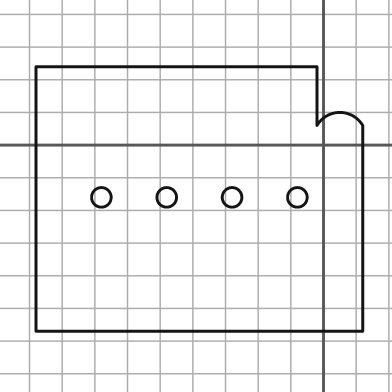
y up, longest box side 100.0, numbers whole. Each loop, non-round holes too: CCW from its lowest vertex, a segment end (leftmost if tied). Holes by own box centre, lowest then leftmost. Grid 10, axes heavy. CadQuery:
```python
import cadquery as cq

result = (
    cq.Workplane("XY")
    .moveTo(-88.0, -57.0)
    .lineTo(12.0, -57.0)
    .lineTo(12.0, 6.0)
    .threePointArc((5.0, 10.0), (-2.0, 6.0))
    .lineTo(-2.0, 24.0)
    .lineTo(-88.0, 24.0)
    .close()
    .moveTo(-68.0, -16.0)
    .circle(3.0)
    .moveTo(-48.0, -16.0)
    .circle(3.0)
    .moveTo(-28.0, -16.0)
    .circle(3.0)
    .moveTo(-8.0, -16.0)
    .circle(3.0)
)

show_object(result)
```